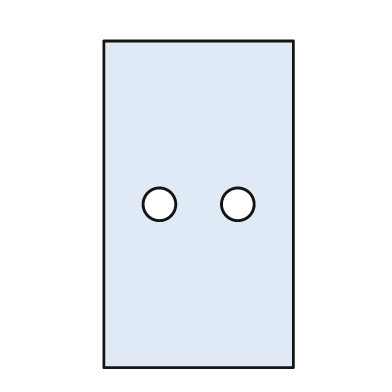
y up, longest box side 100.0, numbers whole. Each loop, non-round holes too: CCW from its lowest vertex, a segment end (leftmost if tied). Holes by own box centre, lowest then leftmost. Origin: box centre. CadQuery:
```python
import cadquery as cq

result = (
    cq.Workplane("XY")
    .moveTo(-29.0, -50.0)
    .lineTo(29.0, -50.0)
    .lineTo(29.0, 50.0)
    .lineTo(-29.0, 50.0)
    .close()
    .moveTo(-12.0, 0.0)
    .circle(5.0)
    .moveTo(12.0, 0.0)
    .circle(5.0)
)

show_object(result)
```